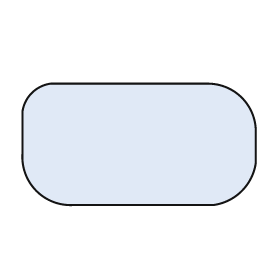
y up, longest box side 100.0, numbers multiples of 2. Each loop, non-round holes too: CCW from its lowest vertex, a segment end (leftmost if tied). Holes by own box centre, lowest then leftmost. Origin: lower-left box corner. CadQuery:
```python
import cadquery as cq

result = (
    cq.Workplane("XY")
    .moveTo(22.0, 0.0)
    .lineTo(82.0, 0.0)
    .threePointArc((94.0, 6.0), (100.0, 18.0))
    .lineTo(100.0, 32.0)
    .threePointArc((94.0, 46.0), (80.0, 52.0))
    .lineTo(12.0, 52.0)
    .threePointArc((4.0, 48.0), (0.0, 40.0))
    .lineTo(0.0, 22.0)
    .threePointArc((6.0, 6.0), (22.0, 0.0))
    .close()
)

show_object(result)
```